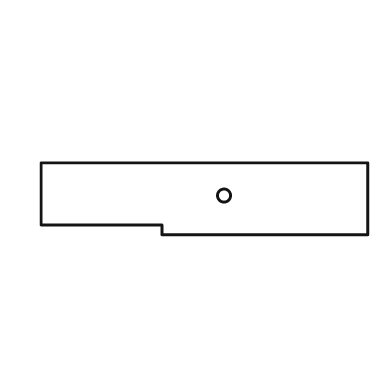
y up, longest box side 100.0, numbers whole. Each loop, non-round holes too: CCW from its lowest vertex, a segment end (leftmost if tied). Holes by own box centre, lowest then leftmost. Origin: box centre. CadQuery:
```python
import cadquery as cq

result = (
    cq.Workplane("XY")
    .moveTo(-13.0, -11.0)
    .lineTo(50.0, -11.0)
    .lineTo(50.0, 11.0)
    .lineTo(-50.0, 11.0)
    .lineTo(-50.0, -8.0)
    .lineTo(-13.0, -8.0)
    .close()
    .moveTo(6.0, 1.0)
    .circle(2.0)
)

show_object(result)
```